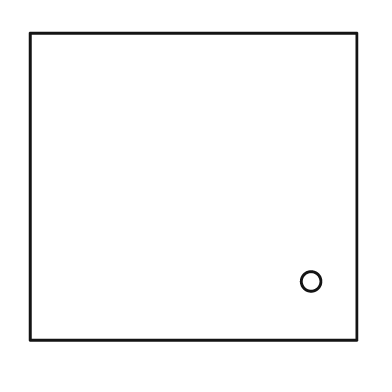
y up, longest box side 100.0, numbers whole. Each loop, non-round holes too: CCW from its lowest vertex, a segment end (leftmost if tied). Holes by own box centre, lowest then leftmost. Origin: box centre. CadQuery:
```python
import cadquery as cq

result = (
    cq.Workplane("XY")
    .moveTo(-50.0, -47.0)
    .lineTo(50.0, -47.0)
    .lineTo(50.0, 47.0)
    .lineTo(-50.0, 47.0)
    .close()
    .moveTo(36.0, -29.0)
    .circle(3.0)
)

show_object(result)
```